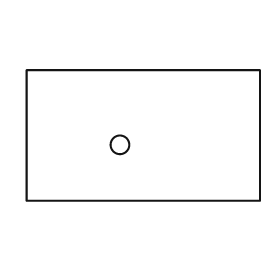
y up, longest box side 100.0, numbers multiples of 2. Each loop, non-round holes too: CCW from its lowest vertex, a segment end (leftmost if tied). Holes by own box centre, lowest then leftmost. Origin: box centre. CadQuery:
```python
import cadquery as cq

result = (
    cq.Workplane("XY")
    .moveTo(-50.0, -28.0)
    .lineTo(50.0, -28.0)
    .lineTo(50.0, 28.0)
    .lineTo(-50.0, 28.0)
    .close()
    .moveTo(-10.0, -4.0)
    .circle(4.0)
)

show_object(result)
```